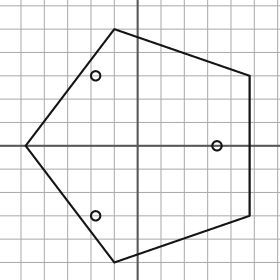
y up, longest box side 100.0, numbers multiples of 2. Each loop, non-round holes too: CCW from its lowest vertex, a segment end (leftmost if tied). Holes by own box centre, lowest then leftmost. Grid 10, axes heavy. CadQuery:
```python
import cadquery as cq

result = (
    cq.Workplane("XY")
    .moveTo(-10.0, -50.0)
    .lineTo(48.0, -30.0)
    .lineTo(48.0, 30.0)
    .lineTo(-10.0, 50.0)
    .lineTo(-48.0, 0.0)
    .close()
    .moveTo(-18.0, -30.0)
    .circle(2.0)
    .moveTo(34.0, 0.0)
    .circle(2.0)
    .moveTo(-18.0, 30.0)
    .circle(2.0)
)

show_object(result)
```